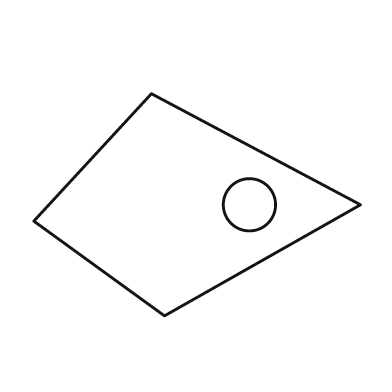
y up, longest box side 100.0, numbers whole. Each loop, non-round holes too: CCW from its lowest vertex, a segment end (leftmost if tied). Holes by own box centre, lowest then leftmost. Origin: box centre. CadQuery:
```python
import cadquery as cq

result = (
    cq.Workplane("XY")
    .moveTo(-10.0, -34.0)
    .lineTo(50.0, 0.0)
    .lineTo(-14.0, 34.0)
    .lineTo(-50.0, -5.0)
    .close()
    .moveTo(16.0, 0.0)
    .circle(8.0)
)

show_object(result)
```